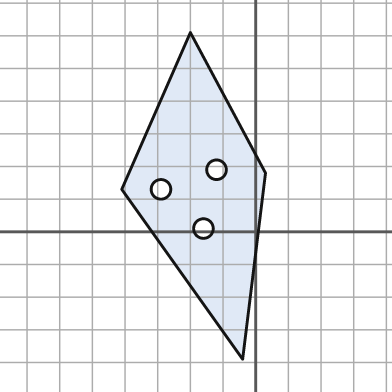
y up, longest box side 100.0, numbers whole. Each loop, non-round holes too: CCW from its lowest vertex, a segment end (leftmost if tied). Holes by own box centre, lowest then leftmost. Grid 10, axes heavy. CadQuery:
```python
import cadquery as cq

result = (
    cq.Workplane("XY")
    .moveTo(-4.0, -39.0)
    .lineTo(3.0, 18.0)
    .lineTo(-20.0, 61.0)
    .lineTo(-41.0, 13.0)
    .close()
    .moveTo(-16.0, 1.0)
    .circle(3.0)
    .moveTo(-29.0, 13.0)
    .circle(3.0)
    .moveTo(-12.0, 19.0)
    .circle(3.0)
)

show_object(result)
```